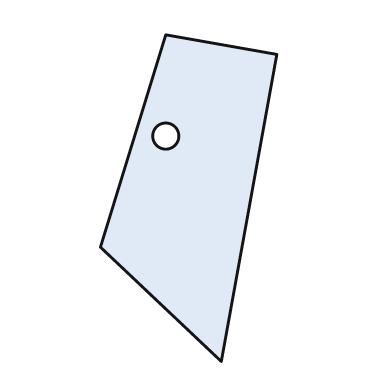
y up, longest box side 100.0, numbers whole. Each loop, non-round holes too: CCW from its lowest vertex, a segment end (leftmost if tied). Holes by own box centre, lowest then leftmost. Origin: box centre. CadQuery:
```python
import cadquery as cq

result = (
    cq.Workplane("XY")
    .moveTo(10.0, -50.0)
    .lineTo(27.0, 44.0)
    .lineTo(-7.0, 50.0)
    .lineTo(-27.0, -15.0)
    .close()
    .moveTo(-7.0, 19.0)
    .circle(4.0)
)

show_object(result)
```